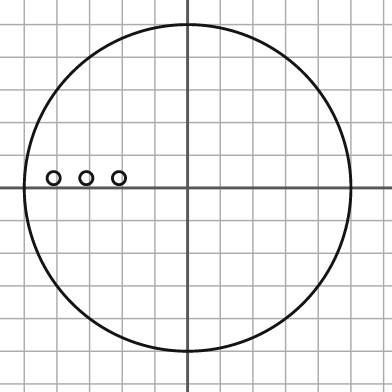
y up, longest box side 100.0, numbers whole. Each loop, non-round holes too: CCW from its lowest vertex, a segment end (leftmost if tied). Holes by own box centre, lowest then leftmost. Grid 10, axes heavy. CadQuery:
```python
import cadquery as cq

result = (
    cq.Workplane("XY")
    .moveTo(0.0, 0.0)
    .circle(50.0)
    .moveTo(-41.0, 3.0)
    .circle(2.0)
    .moveTo(-31.0, 3.0)
    .circle(2.0)
    .moveTo(-21.0, 3.0)
    .circle(2.0)
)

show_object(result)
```